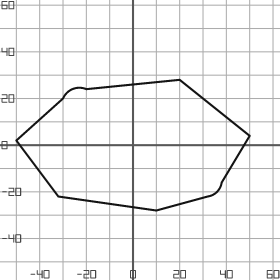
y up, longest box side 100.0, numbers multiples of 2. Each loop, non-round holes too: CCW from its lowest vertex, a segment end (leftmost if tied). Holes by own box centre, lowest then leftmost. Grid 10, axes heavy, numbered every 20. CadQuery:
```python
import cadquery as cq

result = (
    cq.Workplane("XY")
    .moveTo(10.0, -28.0)
    .lineTo(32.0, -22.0)
    .threePointArc((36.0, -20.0), (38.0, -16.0))
    .lineTo(50.0, 4.0)
    .lineTo(20.0, 28.0)
    .lineTo(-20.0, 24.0)
    .threePointArc((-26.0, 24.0), (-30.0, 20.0))
    .lineTo(-50.0, 2.0)
    .lineTo(-32.0, -22.0)
    .close()
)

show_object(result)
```